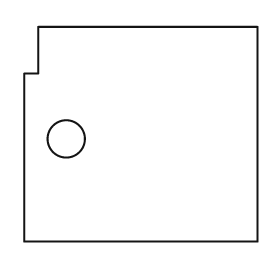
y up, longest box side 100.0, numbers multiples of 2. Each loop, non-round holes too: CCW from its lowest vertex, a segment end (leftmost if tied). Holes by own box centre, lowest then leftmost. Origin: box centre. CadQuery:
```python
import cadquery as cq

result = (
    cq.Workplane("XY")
    .moveTo(-50.0, -46.0)
    .lineTo(50.0, -46.0)
    .lineTo(50.0, 46.0)
    .lineTo(-44.0, 46.0)
    .lineTo(-44.0, 26.0)
    .lineTo(-50.0, 26.0)
    .close()
    .moveTo(-32.0, -2.0)
    .circle(8.0)
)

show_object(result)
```